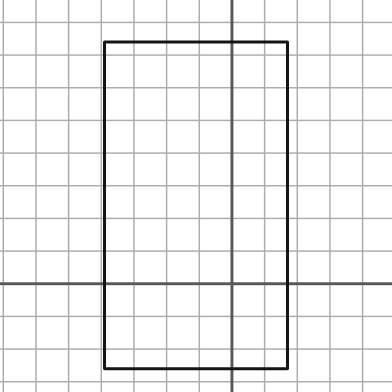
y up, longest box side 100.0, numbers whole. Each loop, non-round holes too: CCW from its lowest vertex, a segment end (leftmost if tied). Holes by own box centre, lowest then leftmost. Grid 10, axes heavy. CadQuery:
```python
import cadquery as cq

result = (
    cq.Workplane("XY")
    .moveTo(-39.0, -26.0)
    .lineTo(17.0, -26.0)
    .lineTo(17.0, 74.0)
    .lineTo(-39.0, 74.0)
    .close()
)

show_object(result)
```